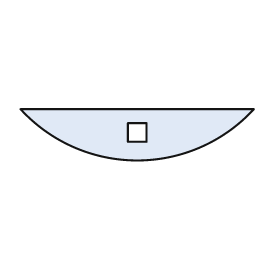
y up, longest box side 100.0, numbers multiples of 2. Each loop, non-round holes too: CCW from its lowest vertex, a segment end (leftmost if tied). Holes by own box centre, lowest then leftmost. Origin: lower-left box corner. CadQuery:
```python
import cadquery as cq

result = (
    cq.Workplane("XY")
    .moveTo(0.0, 22.0)
    .threePointArc((50.0, 0.0), (100.0, 22.0))
    .close()
    .moveTo(46.0, 8.0)
    .lineTo(54.0, 8.0)
    .lineTo(54.0, 16.0)
    .lineTo(46.0, 16.0)
    .close()
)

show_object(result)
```